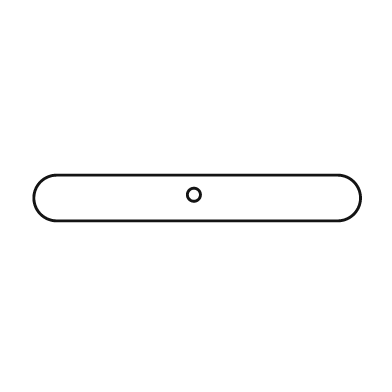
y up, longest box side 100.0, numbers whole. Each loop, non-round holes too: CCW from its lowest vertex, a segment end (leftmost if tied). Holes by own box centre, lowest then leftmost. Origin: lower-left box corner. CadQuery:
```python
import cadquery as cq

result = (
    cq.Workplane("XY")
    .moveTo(7.0, 0.0)
    .lineTo(93.0, 0.0)
    .threePointArc((100.0, 7.0), (93.0, 14.0))
    .lineTo(7.0, 14.0)
    .threePointArc((0.0, 7.0), (7.0, 0.0))
    .close()
    .moveTo(49.0, 8.0)
    .circle(2.0)
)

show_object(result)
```